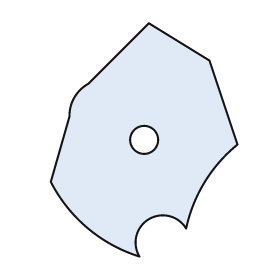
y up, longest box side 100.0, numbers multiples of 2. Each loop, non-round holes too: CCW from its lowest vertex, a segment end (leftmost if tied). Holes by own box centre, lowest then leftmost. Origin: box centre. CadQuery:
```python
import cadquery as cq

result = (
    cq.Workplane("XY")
    .moveTo(-2.0, -50.0)
    .threePointArc((2.0, -34.0), (18.0, -38.0))
    .threePointArc((26.0, -18.0), (40.0, -2.0))
    .lineTo(28.0, 34.0)
    .lineTo(2.0, 50.0)
    .lineTo(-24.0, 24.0)
    .threePointArc((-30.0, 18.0), (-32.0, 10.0))
    .lineTo(-40.0, -18.0)
    .threePointArc((-24.0, -38.0), (-2.0, -50.0))
    .close()
    .moveTo(0.0, 0.0)
    .circle(6.0)
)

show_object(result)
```